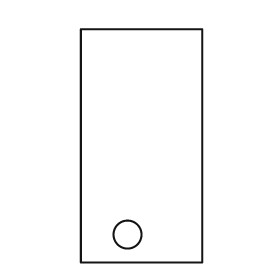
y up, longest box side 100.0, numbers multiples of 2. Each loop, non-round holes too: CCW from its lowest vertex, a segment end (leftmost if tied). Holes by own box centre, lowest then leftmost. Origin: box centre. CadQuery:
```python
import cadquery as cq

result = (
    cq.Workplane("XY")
    .moveTo(-26.0, -50.0)
    .lineTo(26.0, -50.0)
    .lineTo(26.0, 50.0)
    .lineTo(-26.0, 50.0)
    .close()
    .moveTo(-6.0, -38.0)
    .circle(6.0)
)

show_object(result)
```